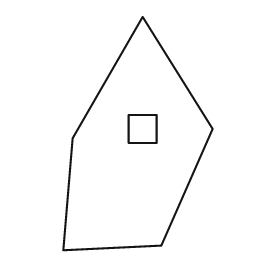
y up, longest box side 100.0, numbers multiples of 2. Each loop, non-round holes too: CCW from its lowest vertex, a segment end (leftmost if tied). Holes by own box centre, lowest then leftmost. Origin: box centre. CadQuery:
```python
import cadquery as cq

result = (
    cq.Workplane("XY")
    .moveTo(-32.0, -50.0)
    .lineTo(10.0, -48.0)
    .lineTo(32.0, 2.0)
    .lineTo(2.0, 50.0)
    .lineTo(-28.0, -2.0)
    .close()
    .moveTo(-4.0, -4.0)
    .lineTo(8.0, -4.0)
    .lineTo(8.0, 8.0)
    .lineTo(-4.0, 8.0)
    .close()
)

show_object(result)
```